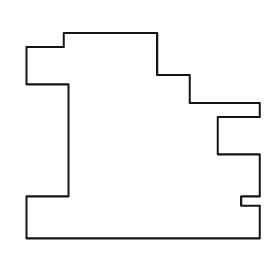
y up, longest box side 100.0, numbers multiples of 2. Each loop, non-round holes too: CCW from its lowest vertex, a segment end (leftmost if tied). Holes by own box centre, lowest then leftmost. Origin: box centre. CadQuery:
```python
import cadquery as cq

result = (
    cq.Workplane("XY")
    .moveTo(-50.0, -44.0)
    .lineTo(50.0, -44.0)
    .lineTo(50.0, -30.0)
    .lineTo(42.0, -30.0)
    .lineTo(42.0, -26.0)
    .lineTo(50.0, -26.0)
    .lineTo(50.0, -8.0)
    .lineTo(32.0, -8.0)
    .lineTo(32.0, 8.0)
    .lineTo(50.0, 8.0)
    .lineTo(50.0, 14.0)
    .lineTo(20.0, 14.0)
    .lineTo(20.0, 26.0)
    .lineTo(6.0, 26.0)
    .lineTo(6.0, 44.0)
    .lineTo(-34.0, 44.0)
    .lineTo(-34.0, 38.0)
    .lineTo(-50.0, 38.0)
    .lineTo(-50.0, 22.0)
    .lineTo(-32.0, 22.0)
    .lineTo(-32.0, -26.0)
    .lineTo(-50.0, -26.0)
    .close()
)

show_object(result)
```